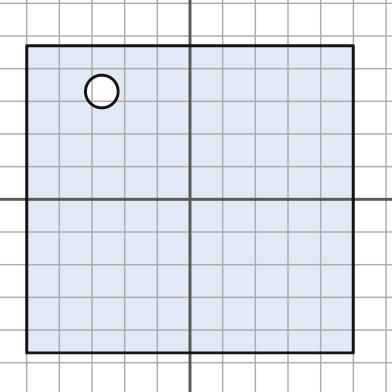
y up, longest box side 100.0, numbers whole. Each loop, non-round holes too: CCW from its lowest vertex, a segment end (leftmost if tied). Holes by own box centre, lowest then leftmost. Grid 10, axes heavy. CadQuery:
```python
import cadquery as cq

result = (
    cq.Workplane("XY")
    .moveTo(-50.0, -47.0)
    .lineTo(50.0, -47.0)
    .lineTo(50.0, 47.0)
    .lineTo(-50.0, 47.0)
    .close()
    .moveTo(-27.0, 33.0)
    .circle(5.0)
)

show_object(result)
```